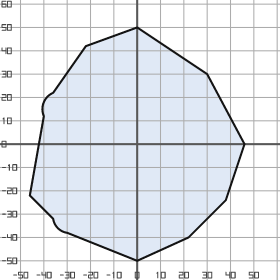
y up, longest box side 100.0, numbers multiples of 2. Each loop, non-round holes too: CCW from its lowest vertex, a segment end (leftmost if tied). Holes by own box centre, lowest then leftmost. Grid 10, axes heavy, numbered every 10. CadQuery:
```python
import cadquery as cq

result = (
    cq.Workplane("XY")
    .moveTo(0.0, -50.0)
    .lineTo(22.0, -40.0)
    .lineTo(38.0, -24.0)
    .lineTo(46.0, 0.0)
    .lineTo(30.0, 30.0)
    .lineTo(0.0, 50.0)
    .lineTo(-22.0, 42.0)
    .lineTo(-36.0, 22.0)
    .threePointArc((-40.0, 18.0), (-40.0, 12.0))
    .lineTo(-46.0, -22.0)
    .lineTo(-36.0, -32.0)
    .threePointArc((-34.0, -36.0), (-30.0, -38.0))
    .close()
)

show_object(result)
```